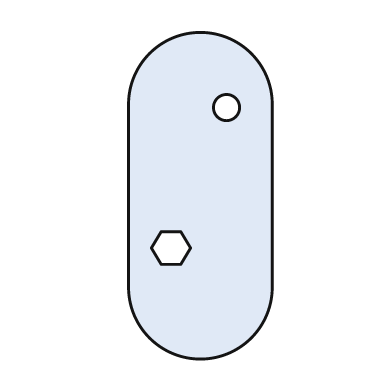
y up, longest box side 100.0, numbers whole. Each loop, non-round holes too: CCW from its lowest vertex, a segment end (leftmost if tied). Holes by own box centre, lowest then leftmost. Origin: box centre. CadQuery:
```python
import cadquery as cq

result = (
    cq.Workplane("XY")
    .moveTo(-22.0, -28.0)
    .threePointArc((0.0, -50.0), (22.0, -28.0))
    .lineTo(22.0, 28.0)
    .threePointArc((0.0, 50.0), (-22.0, 28.0))
    .close()
    .moveTo(-12.0, -21.0)
    .lineTo(-6.0, -21.0)
    .lineTo(-3.0, -16.0)
    .lineTo(-6.0, -11.0)
    .lineTo(-12.0, -11.0)
    .lineTo(-15.0, -16.0)
    .close()
    .moveTo(8.0, 27.0)
    .circle(4.0)
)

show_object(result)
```